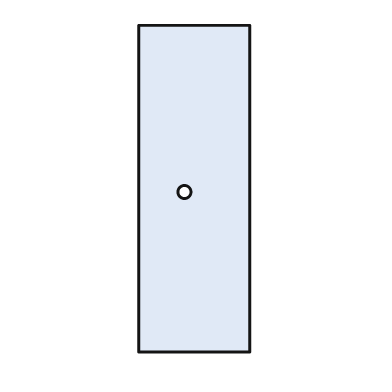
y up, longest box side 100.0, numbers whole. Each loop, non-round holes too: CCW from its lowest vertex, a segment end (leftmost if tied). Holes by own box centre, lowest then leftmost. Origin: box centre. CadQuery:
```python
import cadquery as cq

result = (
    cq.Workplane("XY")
    .moveTo(-17.0, -50.0)
    .lineTo(17.0, -50.0)
    .lineTo(17.0, 50.0)
    .lineTo(-17.0, 50.0)
    .close()
    .moveTo(-3.0, -1.0)
    .circle(2.0)
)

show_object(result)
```